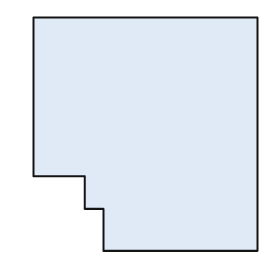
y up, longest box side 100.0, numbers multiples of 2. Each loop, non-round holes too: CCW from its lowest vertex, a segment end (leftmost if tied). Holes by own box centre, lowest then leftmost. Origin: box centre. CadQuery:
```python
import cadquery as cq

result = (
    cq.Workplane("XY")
    .moveTo(-18.0, -50.0)
    .lineTo(48.0, -50.0)
    .lineTo(48.0, 50.0)
    .lineTo(-48.0, 50.0)
    .lineTo(-48.0, -18.0)
    .lineTo(-26.0, -18.0)
    .lineTo(-26.0, -32.0)
    .lineTo(-18.0, -32.0)
    .close()
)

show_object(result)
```